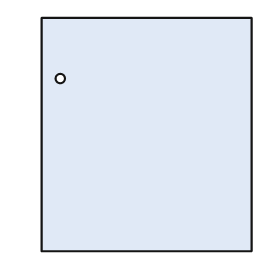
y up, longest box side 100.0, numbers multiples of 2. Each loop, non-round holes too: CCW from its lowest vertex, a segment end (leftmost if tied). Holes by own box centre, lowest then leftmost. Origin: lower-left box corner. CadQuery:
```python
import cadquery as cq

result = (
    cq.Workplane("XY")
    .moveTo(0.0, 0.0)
    .lineTo(90.0, 0.0)
    .lineTo(90.0, 100.0)
    .lineTo(0.0, 100.0)
    .close()
    .moveTo(8.0, 74.0)
    .circle(2.0)
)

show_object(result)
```